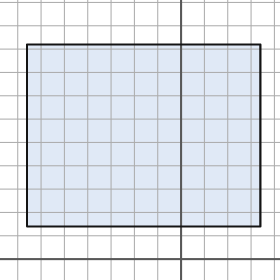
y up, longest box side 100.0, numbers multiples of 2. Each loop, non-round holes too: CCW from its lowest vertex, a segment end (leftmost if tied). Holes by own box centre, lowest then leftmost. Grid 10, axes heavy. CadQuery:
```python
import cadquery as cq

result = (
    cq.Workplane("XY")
    .moveTo(-66.0, 14.0)
    .lineTo(34.0, 14.0)
    .lineTo(34.0, 92.0)
    .lineTo(-66.0, 92.0)
    .close()
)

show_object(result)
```